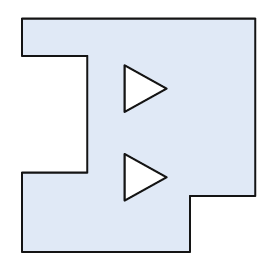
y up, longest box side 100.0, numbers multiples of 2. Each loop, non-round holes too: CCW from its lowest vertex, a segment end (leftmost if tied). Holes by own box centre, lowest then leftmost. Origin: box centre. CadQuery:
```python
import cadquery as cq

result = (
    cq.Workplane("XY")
    .moveTo(-50.0, -50.0)
    .lineTo(22.0, -50.0)
    .lineTo(22.0, -26.0)
    .lineTo(50.0, -26.0)
    .lineTo(50.0, 50.0)
    .lineTo(-50.0, 50.0)
    .lineTo(-50.0, 34.0)
    .lineTo(-22.0, 34.0)
    .lineTo(-22.0, -16.0)
    .lineTo(-50.0, -16.0)
    .close()
    .moveTo(-6.0, -28.0)
    .lineTo(12.0, -18.0)
    .lineTo(-6.0, -8.0)
    .close()
    .moveTo(-6.0, 10.0)
    .lineTo(12.0, 20.0)
    .lineTo(-6.0, 30.0)
    .close()
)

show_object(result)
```